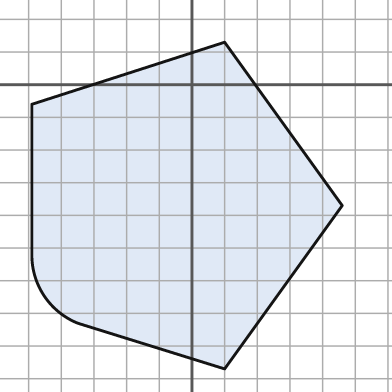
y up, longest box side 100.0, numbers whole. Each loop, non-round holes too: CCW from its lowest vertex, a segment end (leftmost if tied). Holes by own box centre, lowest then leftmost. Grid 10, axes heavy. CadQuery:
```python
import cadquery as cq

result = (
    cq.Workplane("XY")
    .moveTo(10.0, -87.0)
    .lineTo(46.0, -37.0)
    .lineTo(10.0, 13.0)
    .lineTo(-49.0, -6.0)
    .lineTo(-49.0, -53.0)
    .threePointArc((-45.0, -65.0), (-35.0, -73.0))
    .close()
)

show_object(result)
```